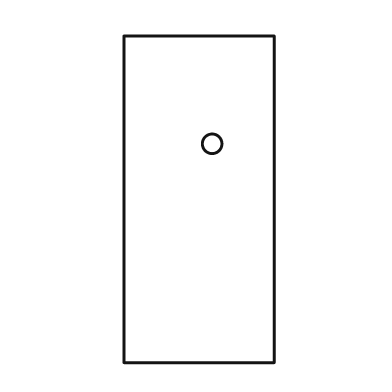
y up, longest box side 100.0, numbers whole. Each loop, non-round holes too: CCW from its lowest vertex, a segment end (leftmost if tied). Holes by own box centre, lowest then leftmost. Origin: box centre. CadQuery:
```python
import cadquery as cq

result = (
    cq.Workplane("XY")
    .moveTo(-23.0, -50.0)
    .lineTo(23.0, -50.0)
    .lineTo(23.0, 50.0)
    .lineTo(-23.0, 50.0)
    .close()
    .moveTo(4.0, 17.0)
    .circle(3.0)
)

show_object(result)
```